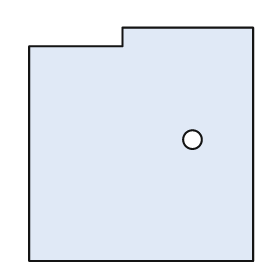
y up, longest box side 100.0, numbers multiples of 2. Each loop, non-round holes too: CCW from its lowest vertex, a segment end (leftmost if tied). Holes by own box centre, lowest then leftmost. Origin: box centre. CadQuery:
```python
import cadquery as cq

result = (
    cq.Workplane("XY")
    .moveTo(-48.0, -50.0)
    .lineTo(48.0, -50.0)
    .lineTo(48.0, 50.0)
    .lineTo(-8.0, 50.0)
    .lineTo(-8.0, 42.0)
    .lineTo(-48.0, 42.0)
    .close()
    .moveTo(22.0, 2.0)
    .circle(4.0)
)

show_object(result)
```